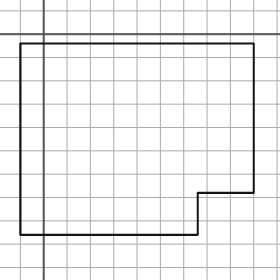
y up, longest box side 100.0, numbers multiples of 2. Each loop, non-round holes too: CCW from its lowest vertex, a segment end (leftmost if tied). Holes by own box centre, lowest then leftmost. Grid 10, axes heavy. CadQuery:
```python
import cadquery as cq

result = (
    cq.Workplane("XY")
    .moveTo(-10.0, -86.0)
    .lineTo(66.0, -86.0)
    .lineTo(66.0, -68.0)
    .lineTo(90.0, -68.0)
    .lineTo(90.0, -4.0)
    .lineTo(-10.0, -4.0)
    .close()
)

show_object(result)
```